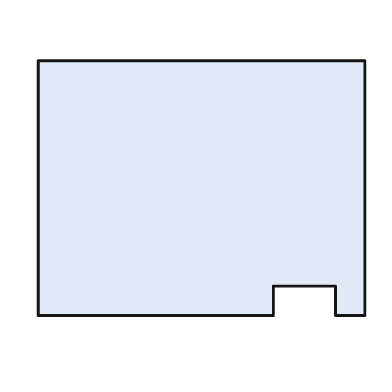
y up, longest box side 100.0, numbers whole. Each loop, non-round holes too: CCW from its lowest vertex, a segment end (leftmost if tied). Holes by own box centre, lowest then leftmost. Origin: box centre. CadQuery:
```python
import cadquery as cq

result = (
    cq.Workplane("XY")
    .moveTo(-50.0, -39.0)
    .lineTo(22.0, -39.0)
    .lineTo(22.0, -30.0)
    .lineTo(41.0, -30.0)
    .lineTo(41.0, -39.0)
    .lineTo(50.0, -39.0)
    .lineTo(50.0, 39.0)
    .lineTo(-50.0, 39.0)
    .close()
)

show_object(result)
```